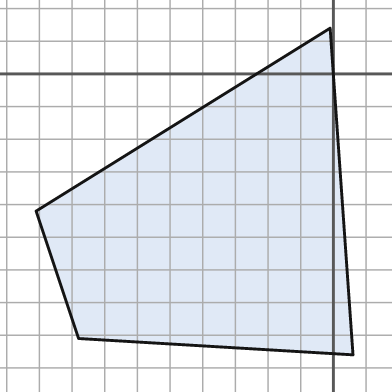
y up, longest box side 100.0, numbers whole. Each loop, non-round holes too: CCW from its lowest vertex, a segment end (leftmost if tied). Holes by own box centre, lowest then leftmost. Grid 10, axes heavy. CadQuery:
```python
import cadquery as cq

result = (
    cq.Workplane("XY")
    .moveTo(6.0, -86.0)
    .lineTo(-1.0, 14.0)
    .lineTo(-91.0, -42.0)
    .lineTo(-78.0, -81.0)
    .close()
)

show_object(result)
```